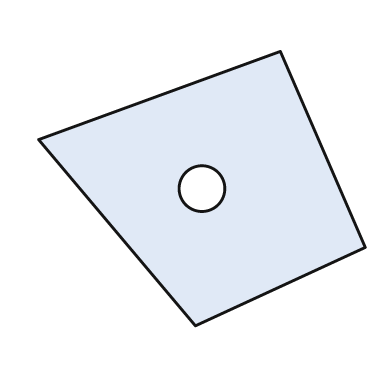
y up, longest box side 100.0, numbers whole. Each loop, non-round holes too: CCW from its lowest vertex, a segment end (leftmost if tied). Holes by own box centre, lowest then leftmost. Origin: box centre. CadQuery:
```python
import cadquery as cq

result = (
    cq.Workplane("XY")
    .moveTo(-2.0, -42.0)
    .lineTo(50.0, -18.0)
    .lineTo(24.0, 42.0)
    .lineTo(-50.0, 15.0)
    .close()
    .moveTo(0.0, 0.0)
    .circle(7.0)
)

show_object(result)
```